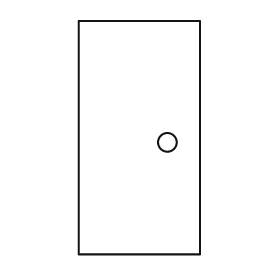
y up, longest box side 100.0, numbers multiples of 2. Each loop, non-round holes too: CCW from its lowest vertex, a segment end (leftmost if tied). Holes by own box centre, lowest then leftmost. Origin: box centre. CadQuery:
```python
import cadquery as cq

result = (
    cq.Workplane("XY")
    .moveTo(-26.0, -50.0)
    .lineTo(26.0, -50.0)
    .lineTo(26.0, 50.0)
    .lineTo(-26.0, 50.0)
    .close()
    .moveTo(12.0, -2.0)
    .circle(4.0)
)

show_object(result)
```